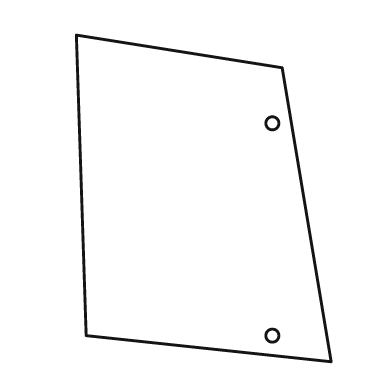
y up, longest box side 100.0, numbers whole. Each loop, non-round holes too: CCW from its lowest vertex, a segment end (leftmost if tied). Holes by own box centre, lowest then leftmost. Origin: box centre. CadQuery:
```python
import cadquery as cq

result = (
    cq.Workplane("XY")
    .moveTo(39.0, -50.0)
    .lineTo(24.0, 40.0)
    .lineTo(-39.0, 50.0)
    .lineTo(-36.0, -42.0)
    .close()
    .moveTo(21.0, -42.0)
    .circle(2.0)
    .moveTo(21.0, 23.0)
    .circle(2.0)
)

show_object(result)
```